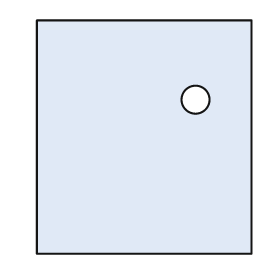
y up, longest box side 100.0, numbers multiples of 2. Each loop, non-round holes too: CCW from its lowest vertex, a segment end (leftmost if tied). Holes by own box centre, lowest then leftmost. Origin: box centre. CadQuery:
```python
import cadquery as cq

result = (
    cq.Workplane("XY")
    .moveTo(-46.0, -50.0)
    .lineTo(46.0, -50.0)
    .lineTo(46.0, 50.0)
    .lineTo(-46.0, 50.0)
    .close()
    .moveTo(22.0, 16.0)
    .circle(6.0)
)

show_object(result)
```